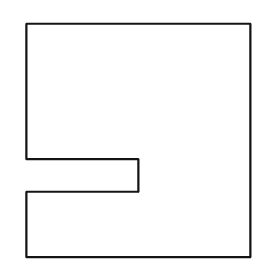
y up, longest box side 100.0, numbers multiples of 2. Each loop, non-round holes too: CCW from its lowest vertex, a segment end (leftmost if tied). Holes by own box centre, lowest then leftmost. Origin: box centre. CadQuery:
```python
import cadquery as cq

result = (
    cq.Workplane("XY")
    .moveTo(-48.0, -50.0)
    .lineTo(48.0, -50.0)
    .lineTo(48.0, 50.0)
    .lineTo(-48.0, 50.0)
    .lineTo(-48.0, -8.0)
    .lineTo(0.0, -8.0)
    .lineTo(0.0, -22.0)
    .lineTo(-48.0, -22.0)
    .close()
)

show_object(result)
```